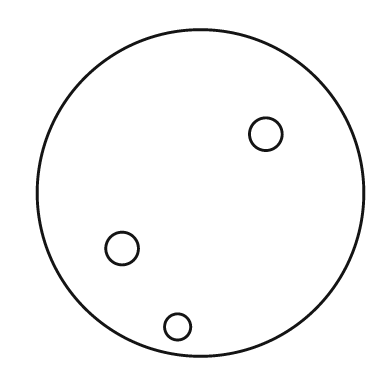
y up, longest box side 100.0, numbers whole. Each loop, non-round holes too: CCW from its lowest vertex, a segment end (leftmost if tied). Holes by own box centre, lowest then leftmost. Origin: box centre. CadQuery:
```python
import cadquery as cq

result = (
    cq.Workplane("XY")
    .moveTo(0.0, 0.0)
    .circle(50.0)
    .moveTo(-7.0, -41.0)
    .circle(4.0)
    .moveTo(-24.0, -17.0)
    .circle(5.0)
    .moveTo(20.0, 18.0)
    .circle(5.0)
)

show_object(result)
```